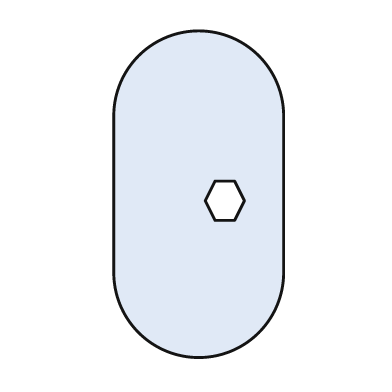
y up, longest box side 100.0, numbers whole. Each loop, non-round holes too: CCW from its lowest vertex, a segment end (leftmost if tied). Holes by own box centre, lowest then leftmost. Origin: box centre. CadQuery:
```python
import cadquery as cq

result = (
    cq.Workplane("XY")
    .moveTo(-26.0, -24.0)
    .threePointArc((0.0, -50.0), (26.0, -24.0))
    .lineTo(26.0, 24.0)
    .threePointArc((0.0, 50.0), (-26.0, 24.0))
    .close()
    .moveTo(5.0, -8.0)
    .lineTo(11.0, -8.0)
    .lineTo(14.0, -2.0)
    .lineTo(11.0, 4.0)
    .lineTo(5.0, 4.0)
    .lineTo(2.0, -2.0)
    .close()
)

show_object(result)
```